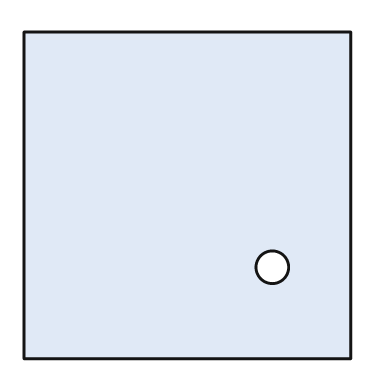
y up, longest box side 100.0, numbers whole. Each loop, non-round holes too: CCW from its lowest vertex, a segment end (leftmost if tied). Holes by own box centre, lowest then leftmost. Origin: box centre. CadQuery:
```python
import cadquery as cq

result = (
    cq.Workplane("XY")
    .moveTo(-50.0, -50.0)
    .lineTo(50.0, -50.0)
    .lineTo(50.0, 50.0)
    .lineTo(-50.0, 50.0)
    .close()
    .moveTo(26.0, -22.0)
    .circle(5.0)
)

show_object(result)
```